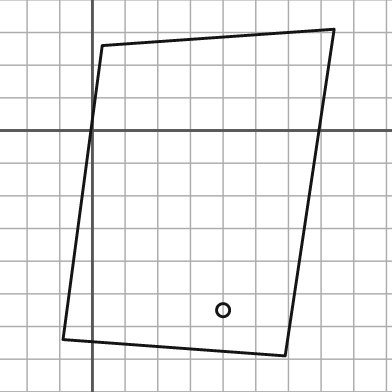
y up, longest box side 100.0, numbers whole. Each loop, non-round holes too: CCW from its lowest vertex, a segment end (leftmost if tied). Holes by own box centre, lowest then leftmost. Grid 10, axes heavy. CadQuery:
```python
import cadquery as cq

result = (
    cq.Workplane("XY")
    .moveTo(59.0, -69.0)
    .lineTo(74.0, 31.0)
    .lineTo(3.0, 26.0)
    .lineTo(-9.0, -64.0)
    .close()
    .moveTo(40.0, -55.0)
    .circle(2.0)
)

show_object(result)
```